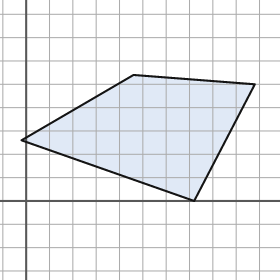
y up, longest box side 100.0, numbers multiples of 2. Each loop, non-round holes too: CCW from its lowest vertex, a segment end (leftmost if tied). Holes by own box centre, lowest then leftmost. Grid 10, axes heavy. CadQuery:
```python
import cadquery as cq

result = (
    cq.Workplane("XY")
    .moveTo(72.0, 0.0)
    .lineTo(98.0, 50.0)
    .lineTo(46.0, 54.0)
    .lineTo(-2.0, 26.0)
    .close()
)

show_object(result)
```